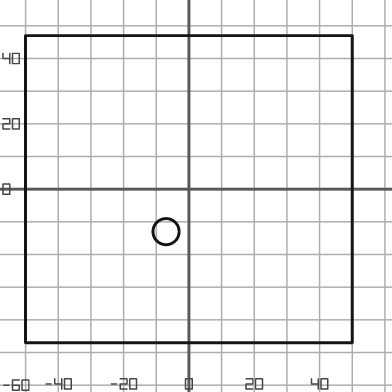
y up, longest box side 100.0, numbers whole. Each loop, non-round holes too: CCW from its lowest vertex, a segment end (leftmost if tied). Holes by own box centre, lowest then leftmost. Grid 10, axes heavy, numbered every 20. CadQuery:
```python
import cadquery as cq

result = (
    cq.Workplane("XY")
    .moveTo(-50.0, -47.0)
    .lineTo(50.0, -47.0)
    .lineTo(50.0, 47.0)
    .lineTo(-50.0, 47.0)
    .close()
    .moveTo(-7.0, -13.0)
    .circle(4.0)
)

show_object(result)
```